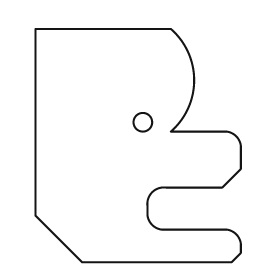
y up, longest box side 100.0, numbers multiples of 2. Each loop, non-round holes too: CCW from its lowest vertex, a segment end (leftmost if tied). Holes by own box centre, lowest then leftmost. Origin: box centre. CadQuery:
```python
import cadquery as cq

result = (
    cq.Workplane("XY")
    .moveTo(-24.0, -50.0)
    .lineTo(40.0, -50.0)
    .lineTo(44.0, -46.0)
    .lineTo(44.0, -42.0)
    .threePointArc((42.0, -38.0), (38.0, -36.0))
    .lineTo(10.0, -36.0)
    .threePointArc((6.0, -34.0), (4.0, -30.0))
    .lineTo(4.0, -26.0)
    .threePointArc((6.0, -20.0), (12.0, -18.0))
    .lineTo(36.0, -18.0)
    .lineTo(44.0, -10.0)
    .lineTo(44.0, 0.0)
    .threePointArc((42.0, 4.0), (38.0, 6.0))
    .lineTo(14.0, 6.0)
    .threePointArc((24.0, 28.0), (14.0, 50.0))
    .lineTo(-44.0, 50.0)
    .lineTo(-44.0, -30.0)
    .close()
    .moveTo(2.0, 10.0)
    .circle(4.0)
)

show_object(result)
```